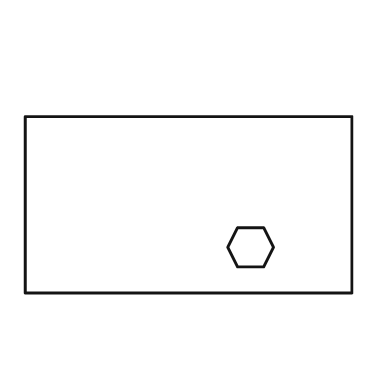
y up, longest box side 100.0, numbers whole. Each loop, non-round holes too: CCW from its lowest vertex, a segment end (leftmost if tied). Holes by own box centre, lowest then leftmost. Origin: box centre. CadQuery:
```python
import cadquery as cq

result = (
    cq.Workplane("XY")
    .moveTo(-50.0, -27.0)
    .lineTo(50.0, -27.0)
    .lineTo(50.0, 27.0)
    .lineTo(-50.0, 27.0)
    .close()
    .moveTo(15.0, -19.0)
    .lineTo(23.0, -19.0)
    .lineTo(26.0, -13.0)
    .lineTo(23.0, -7.0)
    .lineTo(15.0, -7.0)
    .lineTo(12.0, -13.0)
    .close()
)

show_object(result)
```